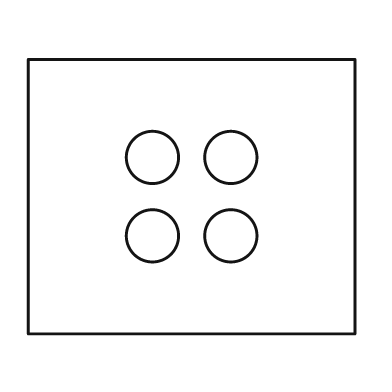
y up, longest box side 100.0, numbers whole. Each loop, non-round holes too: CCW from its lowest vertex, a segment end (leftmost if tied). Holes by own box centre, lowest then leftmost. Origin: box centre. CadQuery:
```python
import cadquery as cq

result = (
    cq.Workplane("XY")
    .moveTo(-50.0, -42.0)
    .lineTo(50.0, -42.0)
    .lineTo(50.0, 42.0)
    .lineTo(-50.0, 42.0)
    .close()
    .moveTo(-12.0, -12.0)
    .circle(8.0)
    .moveTo(12.0, -12.0)
    .circle(8.0)
    .moveTo(-12.0, 12.0)
    .circle(8.0)
    .moveTo(12.0, 12.0)
    .circle(8.0)
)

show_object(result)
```